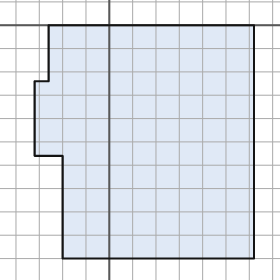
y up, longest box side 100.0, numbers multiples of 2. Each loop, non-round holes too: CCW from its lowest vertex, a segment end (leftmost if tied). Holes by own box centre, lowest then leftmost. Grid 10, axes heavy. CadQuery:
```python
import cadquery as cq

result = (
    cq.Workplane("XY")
    .moveTo(-20.0, -100.0)
    .lineTo(62.0, -100.0)
    .lineTo(62.0, 0.0)
    .lineTo(-26.0, 0.0)
    .lineTo(-26.0, -24.0)
    .lineTo(-32.0, -24.0)
    .lineTo(-32.0, -56.0)
    .lineTo(-20.0, -56.0)
    .close()
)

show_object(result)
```